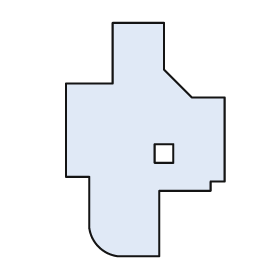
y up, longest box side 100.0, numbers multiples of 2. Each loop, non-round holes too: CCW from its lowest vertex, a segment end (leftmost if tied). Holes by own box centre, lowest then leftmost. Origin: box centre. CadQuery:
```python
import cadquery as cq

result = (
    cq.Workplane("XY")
    .moveTo(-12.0, -50.0)
    .lineTo(6.0, -50.0)
    .lineTo(6.0, -22.0)
    .lineTo(28.0, -22.0)
    .lineTo(28.0, -18.0)
    .lineTo(34.0, -18.0)
    .lineTo(34.0, 18.0)
    .lineTo(20.0, 18.0)
    .lineTo(8.0, 30.0)
    .lineTo(8.0, 50.0)
    .lineTo(-14.0, 50.0)
    .lineTo(-14.0, 24.0)
    .lineTo(-34.0, 24.0)
    .lineTo(-34.0, -16.0)
    .lineTo(-24.0, -16.0)
    .lineTo(-24.0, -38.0)
    .threePointArc((-20.0, -46.0), (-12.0, -50.0))
    .close()
    .moveTo(4.0, -10.0)
    .lineTo(12.0, -10.0)
    .lineTo(12.0, -2.0)
    .lineTo(4.0, -2.0)
    .close()
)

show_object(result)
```